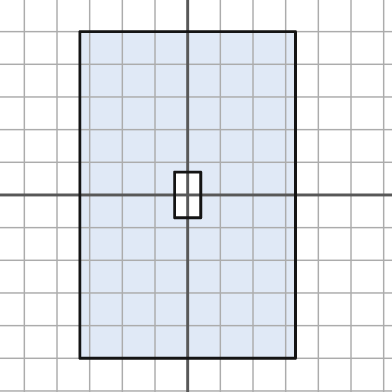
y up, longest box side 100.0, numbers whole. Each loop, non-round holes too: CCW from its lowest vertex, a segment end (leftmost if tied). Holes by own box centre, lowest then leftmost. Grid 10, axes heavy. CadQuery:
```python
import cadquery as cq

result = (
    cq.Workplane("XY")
    .moveTo(-33.0, -50.0)
    .lineTo(33.0, -50.0)
    .lineTo(33.0, 50.0)
    .lineTo(-33.0, 50.0)
    .close()
    .moveTo(-4.0, -7.0)
    .lineTo(4.0, -7.0)
    .lineTo(4.0, 7.0)
    .lineTo(-4.0, 7.0)
    .close()
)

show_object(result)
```